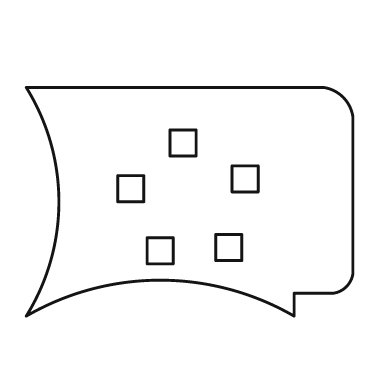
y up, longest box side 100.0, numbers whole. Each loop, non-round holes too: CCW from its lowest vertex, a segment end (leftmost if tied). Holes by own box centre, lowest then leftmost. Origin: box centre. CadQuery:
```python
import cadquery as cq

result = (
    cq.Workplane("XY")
    .moveTo(-50.0, -35.0)
    .threePointArc((-9.0, -24.0), (32.0, -35.0))
    .lineTo(32.0, -28.0)
    .lineTo(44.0, -28.0)
    .threePointArc((48.0, -26.0), (50.0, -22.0))
    .lineTo(50.0, 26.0)
    .threePointArc((47.0, 32.0), (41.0, 35.0))
    .lineTo(-50.0, 35.0)
    .threePointArc((-40.0, 0.0), (-50.0, -35.0))
    .close()
    .moveTo(-13.0, -19.0)
    .lineTo(-5.0, -19.0)
    .lineTo(-5.0, -11.0)
    .lineTo(-13.0, -11.0)
    .close()
    .moveTo(8.0, -18.0)
    .lineTo(16.0, -18.0)
    .lineTo(16.0, -10.0)
    .lineTo(8.0, -10.0)
    .close()
    .moveTo(-22.0, 0.0)
    .lineTo(-14.0, 0.0)
    .lineTo(-14.0, 8.0)
    .lineTo(-22.0, 8.0)
    .close()
    .moveTo(13.0, 3.0)
    .lineTo(21.0, 3.0)
    .lineTo(21.0, 11.0)
    .lineTo(13.0, 11.0)
    .close()
    .moveTo(-6.0, 14.0)
    .lineTo(2.0, 14.0)
    .lineTo(2.0, 22.0)
    .lineTo(-6.0, 22.0)
    .close()
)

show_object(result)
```